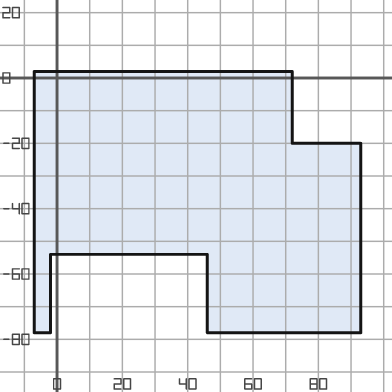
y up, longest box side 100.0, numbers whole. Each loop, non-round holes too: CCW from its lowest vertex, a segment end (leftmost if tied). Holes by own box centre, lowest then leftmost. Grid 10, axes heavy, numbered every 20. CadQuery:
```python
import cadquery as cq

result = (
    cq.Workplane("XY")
    .moveTo(-7.0, -78.0)
    .lineTo(-2.0, -78.0)
    .lineTo(-2.0, -54.0)
    .lineTo(46.0, -54.0)
    .lineTo(46.0, -78.0)
    .lineTo(93.0, -78.0)
    .lineTo(93.0, -20.0)
    .lineTo(72.0, -20.0)
    .lineTo(72.0, 2.0)
    .lineTo(-7.0, 2.0)
    .close()
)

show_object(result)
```